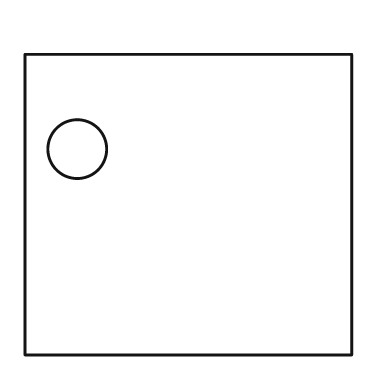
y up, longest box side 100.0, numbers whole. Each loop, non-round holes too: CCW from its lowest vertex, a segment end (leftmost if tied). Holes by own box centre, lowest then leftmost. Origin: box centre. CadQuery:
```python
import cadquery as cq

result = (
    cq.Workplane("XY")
    .moveTo(-50.0, -46.0)
    .lineTo(50.0, -46.0)
    .lineTo(50.0, 46.0)
    .lineTo(-50.0, 46.0)
    .close()
    .moveTo(-34.0, 17.0)
    .circle(9.0)
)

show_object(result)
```